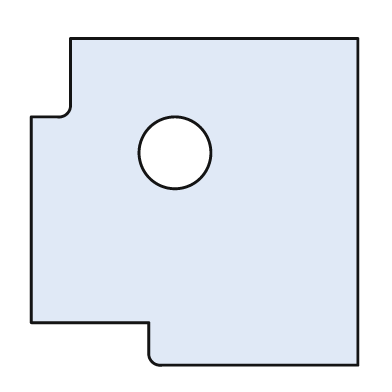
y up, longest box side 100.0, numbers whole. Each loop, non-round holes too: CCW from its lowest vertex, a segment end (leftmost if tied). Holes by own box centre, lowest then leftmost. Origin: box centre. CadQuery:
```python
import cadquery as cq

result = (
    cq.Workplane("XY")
    .moveTo(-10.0, -50.0)
    .lineTo(50.0, -50.0)
    .lineTo(50.0, 50.0)
    .lineTo(-38.0, 50.0)
    .lineTo(-38.0, 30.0)
    .threePointArc((-39.0, 27.0), (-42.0, 26.0))
    .lineTo(-50.0, 26.0)
    .lineTo(-50.0, -37.0)
    .lineTo(-14.0, -37.0)
    .lineTo(-14.0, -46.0)
    .threePointArc((-13.0, -49.0), (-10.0, -50.0))
    .close()
    .moveTo(-6.0, 15.0)
    .circle(11.0)
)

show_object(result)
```